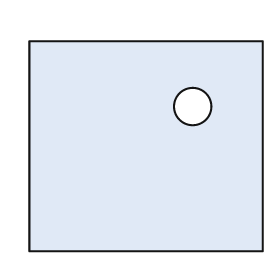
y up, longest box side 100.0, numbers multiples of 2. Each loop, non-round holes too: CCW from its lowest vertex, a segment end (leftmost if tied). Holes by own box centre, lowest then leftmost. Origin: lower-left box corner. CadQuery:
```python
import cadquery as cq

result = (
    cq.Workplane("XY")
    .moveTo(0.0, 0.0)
    .lineTo(100.0, 0.0)
    .lineTo(100.0, 90.0)
    .lineTo(0.0, 90.0)
    .close()
    .moveTo(70.0, 62.0)
    .circle(8.0)
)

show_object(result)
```